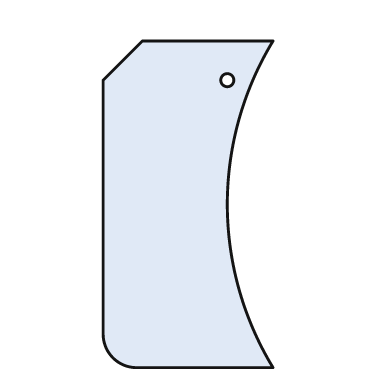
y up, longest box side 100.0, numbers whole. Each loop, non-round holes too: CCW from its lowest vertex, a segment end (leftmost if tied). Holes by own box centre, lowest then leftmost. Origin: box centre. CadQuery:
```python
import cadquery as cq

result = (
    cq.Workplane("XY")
    .moveTo(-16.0, -50.0)
    .lineTo(26.0, -50.0)
    .threePointArc((12.0, 0.0), (26.0, 50.0))
    .lineTo(-14.0, 50.0)
    .lineTo(-26.0, 38.0)
    .lineTo(-26.0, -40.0)
    .threePointArc((-23.0, -47.0), (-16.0, -50.0))
    .close()
    .moveTo(12.0, 38.0)
    .circle(2.0)
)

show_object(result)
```